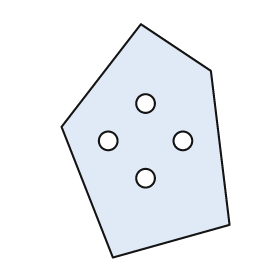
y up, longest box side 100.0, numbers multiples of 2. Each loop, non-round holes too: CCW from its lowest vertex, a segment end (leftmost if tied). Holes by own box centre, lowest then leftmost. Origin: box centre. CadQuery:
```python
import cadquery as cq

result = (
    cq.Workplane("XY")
    .moveTo(-14.0, -50.0)
    .lineTo(36.0, -36.0)
    .lineTo(28.0, 30.0)
    .lineTo(-2.0, 50.0)
    .lineTo(-36.0, 6.0)
    .close()
    .moveTo(0.0, -16.0)
    .circle(4.0)
    .moveTo(-16.0, 0.0)
    .circle(4.0)
    .moveTo(16.0, 0.0)
    .circle(4.0)
    .moveTo(0.0, 16.0)
    .circle(4.0)
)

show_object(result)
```